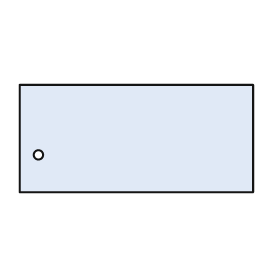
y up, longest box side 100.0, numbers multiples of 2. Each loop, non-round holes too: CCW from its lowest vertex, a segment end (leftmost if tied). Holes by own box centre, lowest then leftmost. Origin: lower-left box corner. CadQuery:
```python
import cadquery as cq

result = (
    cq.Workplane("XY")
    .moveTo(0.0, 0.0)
    .lineTo(100.0, 0.0)
    .lineTo(100.0, 46.0)
    .lineTo(0.0, 46.0)
    .close()
    .moveTo(8.0, 16.0)
    .circle(2.0)
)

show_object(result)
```